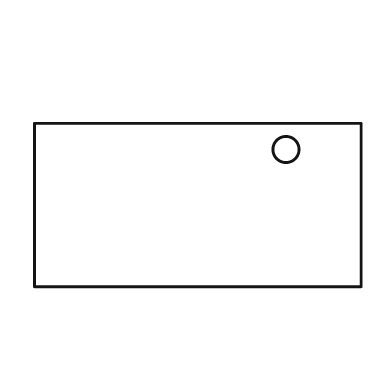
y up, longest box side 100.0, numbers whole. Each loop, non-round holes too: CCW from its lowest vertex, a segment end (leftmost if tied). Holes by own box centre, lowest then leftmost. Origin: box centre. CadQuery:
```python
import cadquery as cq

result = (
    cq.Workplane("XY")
    .moveTo(-50.0, -25.0)
    .lineTo(50.0, -25.0)
    .lineTo(50.0, 25.0)
    .lineTo(-50.0, 25.0)
    .close()
    .moveTo(27.0, 17.0)
    .circle(4.0)
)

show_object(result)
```